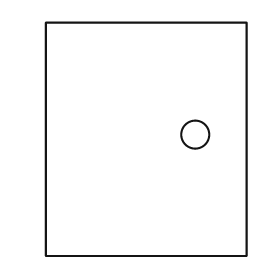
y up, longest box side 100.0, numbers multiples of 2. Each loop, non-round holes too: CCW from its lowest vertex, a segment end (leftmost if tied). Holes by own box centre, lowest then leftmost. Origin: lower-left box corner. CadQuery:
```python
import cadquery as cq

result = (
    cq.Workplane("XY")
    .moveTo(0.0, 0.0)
    .lineTo(86.0, 0.0)
    .lineTo(86.0, 100.0)
    .lineTo(0.0, 100.0)
    .close()
    .moveTo(64.0, 52.0)
    .circle(6.0)
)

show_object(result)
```